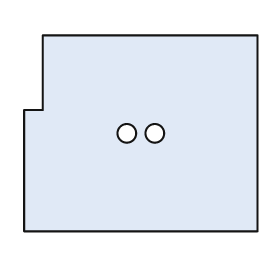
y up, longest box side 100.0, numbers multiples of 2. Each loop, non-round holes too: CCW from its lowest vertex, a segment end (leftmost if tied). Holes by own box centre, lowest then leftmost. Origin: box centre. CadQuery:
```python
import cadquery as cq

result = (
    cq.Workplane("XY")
    .moveTo(-50.0, -42.0)
    .lineTo(50.0, -42.0)
    .lineTo(50.0, 42.0)
    .lineTo(-42.0, 42.0)
    .lineTo(-42.0, 10.0)
    .lineTo(-50.0, 10.0)
    .close()
    .moveTo(-6.0, 0.0)
    .circle(4.0)
    .moveTo(6.0, 0.0)
    .circle(4.0)
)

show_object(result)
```